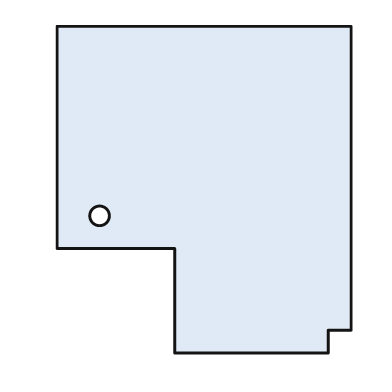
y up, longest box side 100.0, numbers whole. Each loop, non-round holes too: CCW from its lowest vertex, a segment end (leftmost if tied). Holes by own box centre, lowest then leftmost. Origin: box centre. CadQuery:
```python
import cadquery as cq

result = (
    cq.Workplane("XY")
    .moveTo(-9.0, -50.0)
    .lineTo(38.0, -50.0)
    .lineTo(38.0, -43.0)
    .lineTo(45.0, -43.0)
    .lineTo(45.0, 50.0)
    .lineTo(-45.0, 50.0)
    .lineTo(-45.0, -18.0)
    .lineTo(-9.0, -18.0)
    .close()
    .moveTo(-32.0, -8.0)
    .circle(3.0)
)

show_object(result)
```